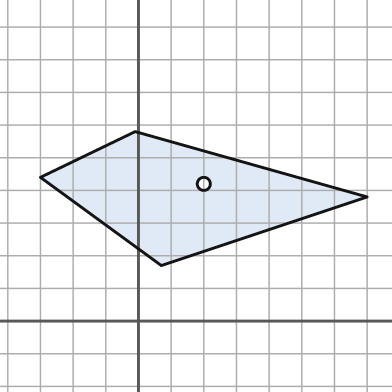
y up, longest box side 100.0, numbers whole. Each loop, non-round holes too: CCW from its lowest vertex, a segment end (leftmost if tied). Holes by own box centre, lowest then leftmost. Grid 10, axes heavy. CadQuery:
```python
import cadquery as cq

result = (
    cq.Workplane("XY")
    .moveTo(7.0, 17.0)
    .lineTo(70.0, 38.0)
    .lineTo(-1.0, 58.0)
    .lineTo(-30.0, 44.0)
    .close()
    .moveTo(20.0, 42.0)
    .circle(2.0)
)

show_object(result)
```